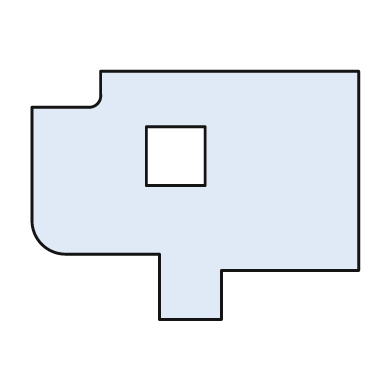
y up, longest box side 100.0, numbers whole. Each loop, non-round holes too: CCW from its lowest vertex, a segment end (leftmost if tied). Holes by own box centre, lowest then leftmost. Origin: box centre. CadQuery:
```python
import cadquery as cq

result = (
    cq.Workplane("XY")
    .moveTo(-11.0, -38.0)
    .lineTo(8.0, -38.0)
    .lineTo(8.0, -23.0)
    .lineTo(50.0, -23.0)
    .lineTo(50.0, 38.0)
    .lineTo(-29.0, 38.0)
    .lineTo(-29.0, 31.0)
    .threePointArc((-30.0, 28.0), (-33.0, 27.0))
    .lineTo(-50.0, 27.0)
    .lineTo(-50.0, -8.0)
    .threePointArc((-47.0, -15.0), (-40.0, -18.0))
    .lineTo(-11.0, -18.0)
    .close()
    .moveTo(-15.0, 3.0)
    .lineTo(3.0, 3.0)
    .lineTo(3.0, 21.0)
    .lineTo(-15.0, 21.0)
    .close()
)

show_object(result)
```